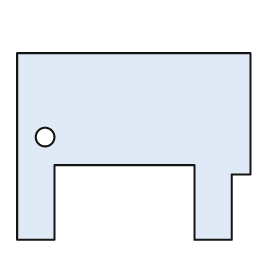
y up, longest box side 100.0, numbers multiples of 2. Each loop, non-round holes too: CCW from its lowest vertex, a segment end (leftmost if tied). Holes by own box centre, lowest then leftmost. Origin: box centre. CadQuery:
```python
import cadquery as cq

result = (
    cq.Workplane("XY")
    .moveTo(-50.0, -40.0)
    .lineTo(-34.0, -40.0)
    .lineTo(-34.0, -8.0)
    .lineTo(26.0, -8.0)
    .lineTo(26.0, -40.0)
    .lineTo(42.0, -40.0)
    .lineTo(42.0, -12.0)
    .lineTo(50.0, -12.0)
    .lineTo(50.0, 40.0)
    .lineTo(-50.0, 40.0)
    .close()
    .moveTo(-38.0, 4.0)
    .circle(4.0)
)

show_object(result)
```